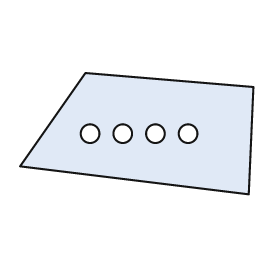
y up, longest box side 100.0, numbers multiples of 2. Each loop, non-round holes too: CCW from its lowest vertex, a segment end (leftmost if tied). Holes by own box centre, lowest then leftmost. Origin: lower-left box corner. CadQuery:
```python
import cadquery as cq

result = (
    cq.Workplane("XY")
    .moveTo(98.0, 0.0)
    .lineTo(100.0, 46.0)
    .lineTo(28.0, 52.0)
    .lineTo(0.0, 12.0)
    .close()
    .moveTo(30.0, 26.0)
    .circle(4.0)
    .moveTo(44.0, 26.0)
    .circle(4.0)
    .moveTo(58.0, 26.0)
    .circle(4.0)
    .moveTo(72.0, 26.0)
    .circle(4.0)
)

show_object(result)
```